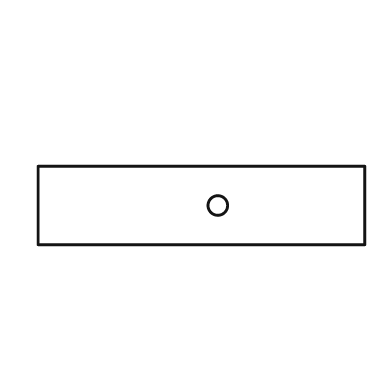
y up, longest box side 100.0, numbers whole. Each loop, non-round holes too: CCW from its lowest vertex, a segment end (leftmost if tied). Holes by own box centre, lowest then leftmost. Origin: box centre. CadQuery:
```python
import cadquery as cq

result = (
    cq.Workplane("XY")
    .moveTo(-50.0, -12.0)
    .lineTo(50.0, -12.0)
    .lineTo(50.0, 12.0)
    .lineTo(-50.0, 12.0)
    .close()
    .moveTo(5.0, 0.0)
    .circle(3.0)
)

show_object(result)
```